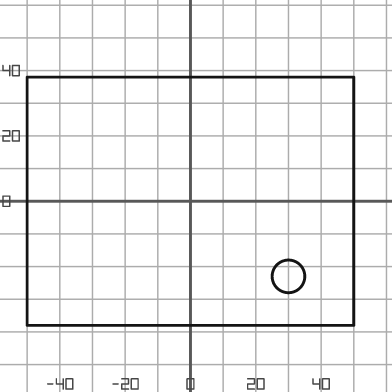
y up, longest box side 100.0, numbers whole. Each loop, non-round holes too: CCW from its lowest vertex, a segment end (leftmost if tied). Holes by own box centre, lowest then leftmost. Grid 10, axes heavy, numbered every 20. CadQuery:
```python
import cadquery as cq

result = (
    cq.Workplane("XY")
    .moveTo(-50.0, -38.0)
    .lineTo(50.0, -38.0)
    .lineTo(50.0, 38.0)
    .lineTo(-50.0, 38.0)
    .close()
    .moveTo(30.0, -23.0)
    .circle(5.0)
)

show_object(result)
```